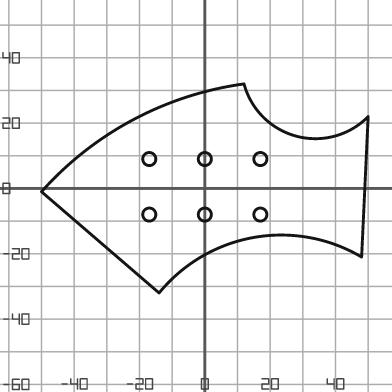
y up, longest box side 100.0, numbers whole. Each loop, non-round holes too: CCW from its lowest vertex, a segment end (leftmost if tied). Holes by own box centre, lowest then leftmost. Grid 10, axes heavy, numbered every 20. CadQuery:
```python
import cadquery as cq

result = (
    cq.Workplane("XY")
    .moveTo(-14.0, -32.0)
    .threePointArc((15.0, -15.0), (48.0, -21.0))
    .lineTo(50.0, 22.0)
    .threePointArc((28.0, 16.0), (12.0, 32.0))
    .threePointArc((-22.0, 21.0), (-50.0, -1.0))
    .close()
    .moveTo(-17.0, -8.0)
    .circle(2.0)
    .moveTo(0.0, -8.0)
    .circle(2.0)
    .moveTo(17.0, -8.0)
    .circle(2.0)
    .moveTo(-17.0, 9.0)
    .circle(2.0)
    .moveTo(0.0, 9.0)
    .circle(2.0)
    .moveTo(17.0, 9.0)
    .circle(2.0)
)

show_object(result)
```